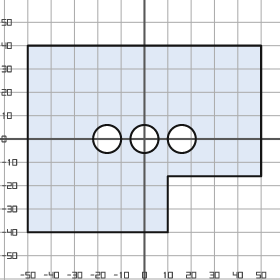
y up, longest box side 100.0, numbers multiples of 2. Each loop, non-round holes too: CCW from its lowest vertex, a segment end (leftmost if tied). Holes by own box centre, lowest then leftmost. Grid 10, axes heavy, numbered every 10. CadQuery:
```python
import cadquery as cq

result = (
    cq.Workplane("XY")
    .moveTo(-50.0, -40.0)
    .lineTo(10.0, -40.0)
    .lineTo(10.0, -16.0)
    .lineTo(50.0, -16.0)
    .lineTo(50.0, 40.0)
    .lineTo(-50.0, 40.0)
    .close()
    .moveTo(-16.0, 0.0)
    .circle(6.0)
    .moveTo(0.0, 0.0)
    .circle(6.0)
    .moveTo(16.0, 0.0)
    .circle(6.0)
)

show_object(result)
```